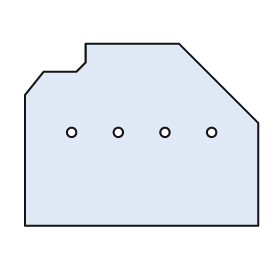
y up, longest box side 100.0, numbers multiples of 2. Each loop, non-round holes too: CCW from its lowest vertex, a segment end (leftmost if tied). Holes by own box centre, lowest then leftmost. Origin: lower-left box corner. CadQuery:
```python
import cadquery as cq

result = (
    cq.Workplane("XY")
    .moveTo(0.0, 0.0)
    .lineTo(100.0, 0.0)
    .lineTo(100.0, 44.0)
    .lineTo(66.0, 78.0)
    .lineTo(26.0, 78.0)
    .lineTo(26.0, 70.0)
    .lineTo(22.0, 66.0)
    .lineTo(8.0, 66.0)
    .lineTo(0.0, 56.0)
    .close()
    .moveTo(20.0, 40.0)
    .circle(2.0)
    .moveTo(40.0, 40.0)
    .circle(2.0)
    .moveTo(60.0, 40.0)
    .circle(2.0)
    .moveTo(80.0, 40.0)
    .circle(2.0)
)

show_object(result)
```